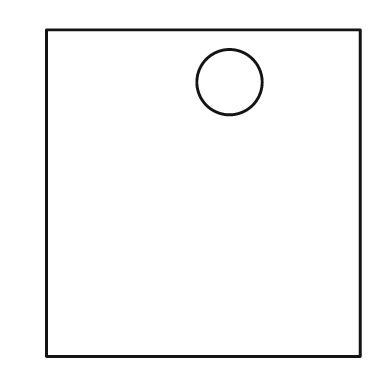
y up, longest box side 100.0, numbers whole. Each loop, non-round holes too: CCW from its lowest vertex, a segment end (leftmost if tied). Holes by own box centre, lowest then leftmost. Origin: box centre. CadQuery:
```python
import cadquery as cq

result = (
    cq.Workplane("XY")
    .moveTo(-48.0, -50.0)
    .lineTo(48.0, -50.0)
    .lineTo(48.0, 50.0)
    .lineTo(-48.0, 50.0)
    .close()
    .moveTo(8.0, 34.0)
    .circle(10.0)
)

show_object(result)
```